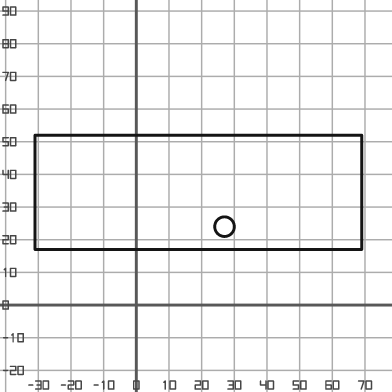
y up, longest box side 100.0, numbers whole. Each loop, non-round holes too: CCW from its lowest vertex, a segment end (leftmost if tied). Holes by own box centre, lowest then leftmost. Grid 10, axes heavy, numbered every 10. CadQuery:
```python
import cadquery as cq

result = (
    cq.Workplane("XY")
    .moveTo(-31.0, 17.0)
    .lineTo(69.0, 17.0)
    .lineTo(69.0, 52.0)
    .lineTo(-31.0, 52.0)
    .close()
    .moveTo(27.0, 24.0)
    .circle(3.0)
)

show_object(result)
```